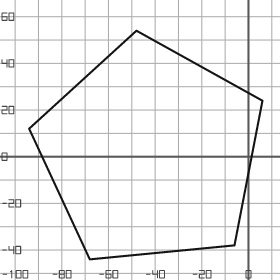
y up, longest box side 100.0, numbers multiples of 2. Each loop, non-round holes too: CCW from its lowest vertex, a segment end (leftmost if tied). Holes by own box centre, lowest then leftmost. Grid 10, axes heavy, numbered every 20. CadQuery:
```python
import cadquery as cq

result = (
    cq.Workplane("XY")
    .moveTo(-68.0, -44.0)
    .lineTo(-6.0, -38.0)
    .lineTo(6.0, 24.0)
    .lineTo(-48.0, 54.0)
    .lineTo(-94.0, 12.0)
    .close()
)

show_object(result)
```